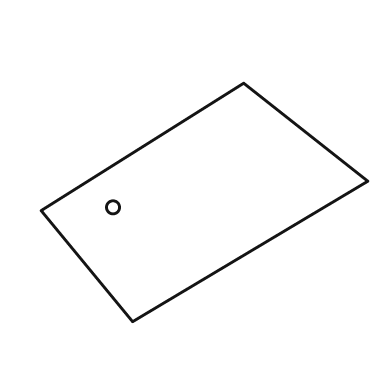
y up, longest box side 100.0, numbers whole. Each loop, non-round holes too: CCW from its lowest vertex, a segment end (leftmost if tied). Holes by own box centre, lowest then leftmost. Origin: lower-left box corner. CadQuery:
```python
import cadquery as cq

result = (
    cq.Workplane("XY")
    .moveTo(28.0, 0.0)
    .lineTo(100.0, 43.0)
    .lineTo(62.0, 73.0)
    .lineTo(0.0, 34.0)
    .close()
    .moveTo(22.0, 35.0)
    .circle(2.0)
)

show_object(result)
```